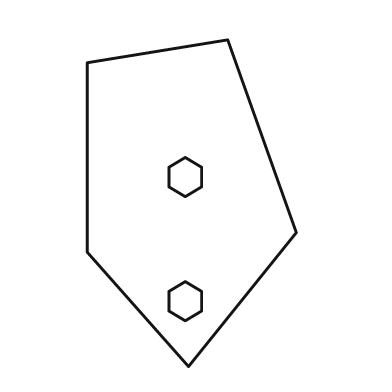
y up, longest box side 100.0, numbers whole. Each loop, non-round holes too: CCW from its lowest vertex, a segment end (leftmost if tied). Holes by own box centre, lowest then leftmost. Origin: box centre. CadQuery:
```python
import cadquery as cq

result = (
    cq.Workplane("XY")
    .moveTo(-1.0, -50.0)
    .lineTo(32.0, -9.0)
    .lineTo(11.0, 50.0)
    .lineTo(-32.0, 43.0)
    .lineTo(-32.0, -15.0)
    .close()
    .moveTo(-2.0, -36.0)
    .lineTo(3.0, -33.0)
    .lineTo(3.0, -27.0)
    .lineTo(-2.0, -24.0)
    .lineTo(-7.0, -27.0)
    .lineTo(-7.0, -33.0)
    .close()
    .moveTo(-2.0, 2.0)
    .lineTo(3.0, 5.0)
    .lineTo(3.0, 11.0)
    .lineTo(-2.0, 14.0)
    .lineTo(-7.0, 11.0)
    .lineTo(-7.0, 5.0)
    .close()
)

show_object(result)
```